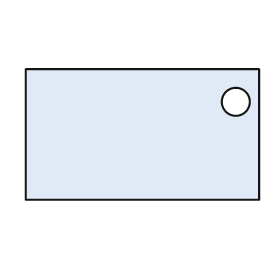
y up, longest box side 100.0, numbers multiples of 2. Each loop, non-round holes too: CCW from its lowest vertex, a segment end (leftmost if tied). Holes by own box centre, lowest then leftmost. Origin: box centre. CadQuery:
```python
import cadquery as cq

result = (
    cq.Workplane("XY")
    .moveTo(-50.0, -28.0)
    .lineTo(50.0, -28.0)
    .lineTo(50.0, 28.0)
    .lineTo(-50.0, 28.0)
    .close()
    .moveTo(40.0, 14.0)
    .circle(6.0)
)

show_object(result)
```